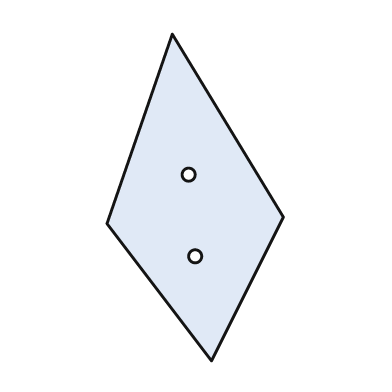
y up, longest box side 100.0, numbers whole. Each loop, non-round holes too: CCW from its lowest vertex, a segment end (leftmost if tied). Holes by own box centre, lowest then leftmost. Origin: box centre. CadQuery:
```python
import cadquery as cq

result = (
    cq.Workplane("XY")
    .moveTo(5.0, -50.0)
    .lineTo(27.0, -6.0)
    .lineTo(-7.0, 50.0)
    .lineTo(-27.0, -8.0)
    .close()
    .moveTo(0.0, -18.0)
    .circle(2.0)
    .moveTo(-2.0, 7.0)
    .circle(2.0)
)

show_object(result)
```